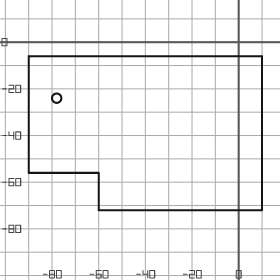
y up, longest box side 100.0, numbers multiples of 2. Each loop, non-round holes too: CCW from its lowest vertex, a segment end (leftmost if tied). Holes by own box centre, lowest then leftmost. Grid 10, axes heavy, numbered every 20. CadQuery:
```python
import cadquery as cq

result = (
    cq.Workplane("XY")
    .moveTo(-60.0, -72.0)
    .lineTo(10.0, -72.0)
    .lineTo(10.0, -6.0)
    .lineTo(-90.0, -6.0)
    .lineTo(-90.0, -56.0)
    .lineTo(-60.0, -56.0)
    .close()
    .moveTo(-78.0, -24.0)
    .circle(2.0)
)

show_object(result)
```